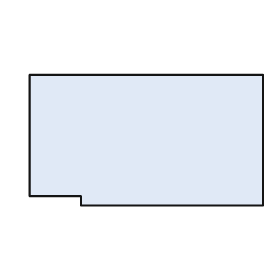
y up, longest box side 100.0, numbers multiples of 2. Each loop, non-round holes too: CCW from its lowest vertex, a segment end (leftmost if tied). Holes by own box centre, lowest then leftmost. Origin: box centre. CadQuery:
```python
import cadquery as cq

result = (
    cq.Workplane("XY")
    .moveTo(-28.0, -28.0)
    .lineTo(50.0, -28.0)
    .lineTo(50.0, 28.0)
    .lineTo(-50.0, 28.0)
    .lineTo(-50.0, -24.0)
    .lineTo(-28.0, -24.0)
    .close()
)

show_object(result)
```